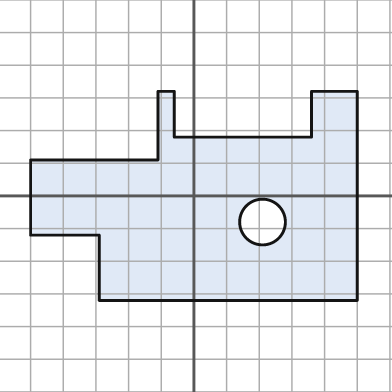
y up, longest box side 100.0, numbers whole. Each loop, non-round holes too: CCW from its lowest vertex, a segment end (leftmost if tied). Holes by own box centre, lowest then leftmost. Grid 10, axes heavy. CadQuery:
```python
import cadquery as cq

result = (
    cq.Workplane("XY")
    .moveTo(-29.0, -32.0)
    .lineTo(50.0, -32.0)
    .lineTo(50.0, 32.0)
    .lineTo(36.0, 32.0)
    .lineTo(36.0, 18.0)
    .lineTo(-6.0, 18.0)
    .lineTo(-6.0, 32.0)
    .lineTo(-11.0, 32.0)
    .lineTo(-11.0, 11.0)
    .lineTo(-50.0, 11.0)
    .lineTo(-50.0, -12.0)
    .lineTo(-29.0, -12.0)
    .close()
    .moveTo(21.0, -8.0)
    .circle(7.0)
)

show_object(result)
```